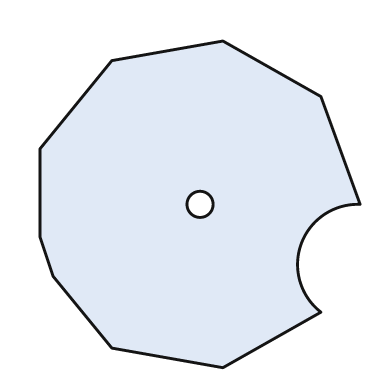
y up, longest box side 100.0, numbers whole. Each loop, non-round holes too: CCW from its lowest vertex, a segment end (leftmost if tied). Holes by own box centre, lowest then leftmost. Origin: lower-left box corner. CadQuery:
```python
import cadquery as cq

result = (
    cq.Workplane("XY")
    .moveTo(56.0, 0.0)
    .lineTo(86.0, 17.0)
    .threePointArc((80.0, 38.0), (98.0, 50.0))
    .lineTo(86.0, 83.0)
    .lineTo(56.0, 100.0)
    .lineTo(22.0, 94.0)
    .lineTo(0.0, 67.0)
    .lineTo(0.0, 40.0)
    .lineTo(4.0, 28.0)
    .lineTo(22.0, 6.0)
    .close()
    .moveTo(49.0, 50.0)
    .circle(4.0)
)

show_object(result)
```